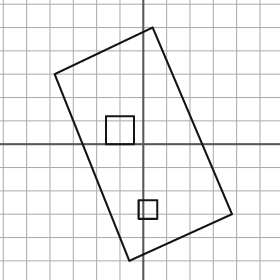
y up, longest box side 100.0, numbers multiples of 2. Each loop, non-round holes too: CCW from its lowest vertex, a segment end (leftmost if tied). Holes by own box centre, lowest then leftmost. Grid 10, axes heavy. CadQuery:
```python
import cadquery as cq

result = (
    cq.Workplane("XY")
    .moveTo(-6.0, -50.0)
    .lineTo(38.0, -30.0)
    .lineTo(4.0, 50.0)
    .lineTo(-38.0, 30.0)
    .close()
    .moveTo(-2.0, -32.0)
    .lineTo(6.0, -32.0)
    .lineTo(6.0, -24.0)
    .lineTo(-2.0, -24.0)
    .close()
    .moveTo(-16.0, 0.0)
    .lineTo(-4.0, 0.0)
    .lineTo(-4.0, 12.0)
    .lineTo(-16.0, 12.0)
    .close()
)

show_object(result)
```